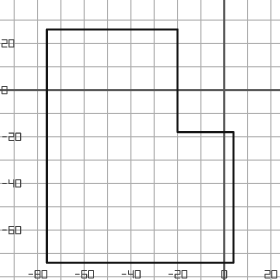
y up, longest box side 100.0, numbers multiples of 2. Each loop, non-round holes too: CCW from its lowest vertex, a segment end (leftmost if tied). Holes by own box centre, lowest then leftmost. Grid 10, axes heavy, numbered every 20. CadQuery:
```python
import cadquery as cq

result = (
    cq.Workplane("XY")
    .moveTo(-76.0, -74.0)
    .lineTo(4.0, -74.0)
    .lineTo(4.0, -18.0)
    .lineTo(-20.0, -18.0)
    .lineTo(-20.0, 26.0)
    .lineTo(-76.0, 26.0)
    .close()
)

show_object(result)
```